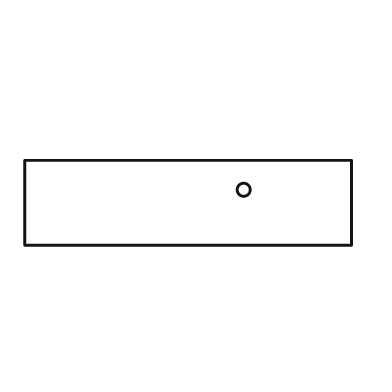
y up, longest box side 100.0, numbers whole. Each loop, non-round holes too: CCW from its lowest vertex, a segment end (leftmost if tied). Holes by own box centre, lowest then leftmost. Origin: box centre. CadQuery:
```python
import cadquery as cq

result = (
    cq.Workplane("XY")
    .moveTo(-50.0, -13.0)
    .lineTo(50.0, -13.0)
    .lineTo(50.0, 13.0)
    .lineTo(-50.0, 13.0)
    .close()
    .moveTo(17.0, 4.0)
    .circle(2.0)
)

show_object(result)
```